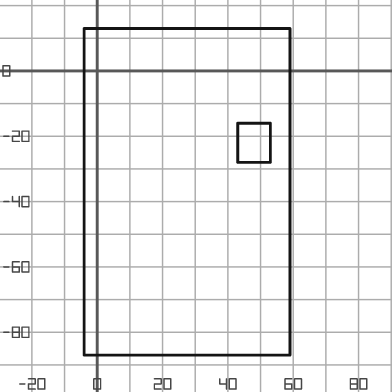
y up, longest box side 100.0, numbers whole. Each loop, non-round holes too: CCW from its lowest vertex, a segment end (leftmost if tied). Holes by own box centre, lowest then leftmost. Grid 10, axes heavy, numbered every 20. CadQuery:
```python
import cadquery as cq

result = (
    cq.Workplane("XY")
    .moveTo(-4.0, -87.0)
    .lineTo(59.0, -87.0)
    .lineTo(59.0, 13.0)
    .lineTo(-4.0, 13.0)
    .close()
    .moveTo(43.0, -28.0)
    .lineTo(53.0, -28.0)
    .lineTo(53.0, -16.0)
    .lineTo(43.0, -16.0)
    .close()
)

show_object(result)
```